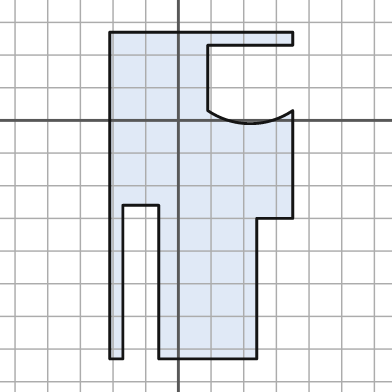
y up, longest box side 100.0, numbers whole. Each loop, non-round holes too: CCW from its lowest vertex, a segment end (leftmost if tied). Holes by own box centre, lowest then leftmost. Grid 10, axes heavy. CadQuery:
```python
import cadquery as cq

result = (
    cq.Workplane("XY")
    .moveTo(-21.0, -73.0)
    .lineTo(-17.0, -73.0)
    .lineTo(-17.0, -26.0)
    .lineTo(-6.0, -26.0)
    .lineTo(-6.0, -73.0)
    .lineTo(24.0, -73.0)
    .lineTo(24.0, -30.0)
    .lineTo(35.0, -30.0)
    .lineTo(35.0, 3.0)
    .threePointArc((22.0, -1.0), (9.0, 3.0))
    .lineTo(9.0, 23.0)
    .lineTo(35.0, 23.0)
    .lineTo(35.0, 27.0)
    .lineTo(-21.0, 27.0)
    .close()
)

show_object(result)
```